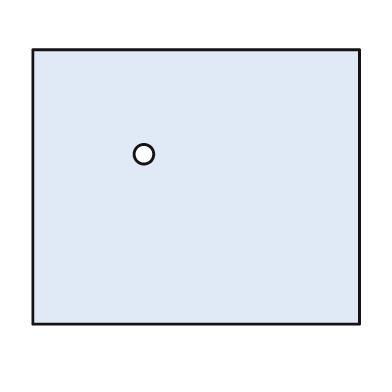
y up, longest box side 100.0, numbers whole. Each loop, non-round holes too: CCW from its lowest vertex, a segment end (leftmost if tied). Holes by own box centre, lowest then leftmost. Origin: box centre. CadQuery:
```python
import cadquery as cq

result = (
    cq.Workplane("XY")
    .moveTo(-50.0, -42.0)
    .lineTo(50.0, -42.0)
    .lineTo(50.0, 42.0)
    .lineTo(-50.0, 42.0)
    .close()
    .moveTo(-16.0, 10.0)
    .circle(3.0)
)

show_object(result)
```